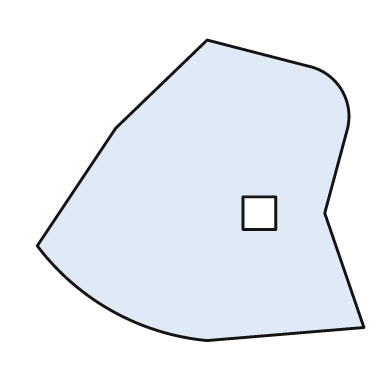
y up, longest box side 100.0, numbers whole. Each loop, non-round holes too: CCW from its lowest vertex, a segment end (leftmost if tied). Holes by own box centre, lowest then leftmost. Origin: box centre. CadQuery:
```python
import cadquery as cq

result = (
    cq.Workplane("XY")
    .moveTo(2.0, -46.0)
    .lineTo(50.0, -42.0)
    .lineTo(38.0, -7.0)
    .lineTo(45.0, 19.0)
    .threePointArc((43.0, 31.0), (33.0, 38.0))
    .lineTo(2.0, 46.0)
    .lineTo(-26.0, 19.0)
    .lineTo(-50.0, -17.0)
    .threePointArc((-27.0, -37.0), (2.0, -46.0))
    .close()
    .moveTo(13.0, -12.0)
    .lineTo(23.0, -12.0)
    .lineTo(23.0, -2.0)
    .lineTo(13.0, -2.0)
    .close()
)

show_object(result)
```